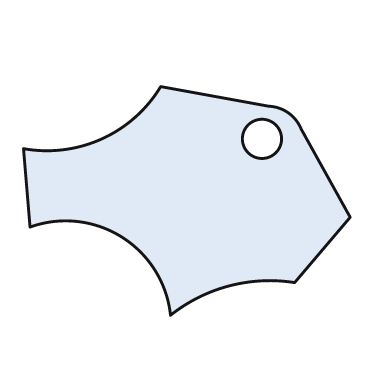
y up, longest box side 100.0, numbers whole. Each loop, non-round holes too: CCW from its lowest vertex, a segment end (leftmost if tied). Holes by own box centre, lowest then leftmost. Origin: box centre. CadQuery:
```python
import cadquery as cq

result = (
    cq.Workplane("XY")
    .moveTo(-5.0, -35.0)
    .threePointArc((13.0, -26.0), (33.0, -25.0))
    .lineTo(50.0, -5.0)
    .lineTo(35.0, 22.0)
    .threePointArc((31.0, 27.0), (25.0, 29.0))
    .lineTo(-8.0, 35.0)
    .threePointArc((-26.0, 19.0), (-50.0, 16.0))
    .lineTo(-48.0, -8.0)
    .threePointArc((-20.0, -11.0), (-5.0, -35.0))
    .close()
    .moveTo(23.0, 19.0)
    .circle(6.0)
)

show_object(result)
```